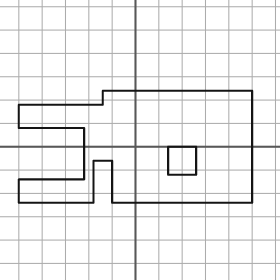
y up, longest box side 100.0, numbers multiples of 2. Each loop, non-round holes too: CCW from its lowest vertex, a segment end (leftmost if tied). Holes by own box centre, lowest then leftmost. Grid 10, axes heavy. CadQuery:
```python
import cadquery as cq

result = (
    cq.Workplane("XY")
    .moveTo(-50.0, -24.0)
    .lineTo(-18.0, -24.0)
    .lineTo(-18.0, -6.0)
    .lineTo(-10.0, -6.0)
    .lineTo(-10.0, -24.0)
    .lineTo(50.0, -24.0)
    .lineTo(50.0, 24.0)
    .lineTo(-14.0, 24.0)
    .lineTo(-14.0, 18.0)
    .lineTo(-50.0, 18.0)
    .lineTo(-50.0, 8.0)
    .lineTo(-22.0, 8.0)
    .lineTo(-22.0, -14.0)
    .lineTo(-50.0, -14.0)
    .close()
    .moveTo(14.0, -12.0)
    .lineTo(26.0, -12.0)
    .lineTo(26.0, 0.0)
    .lineTo(14.0, 0.0)
    .close()
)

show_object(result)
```